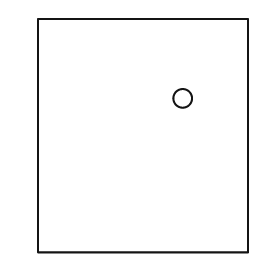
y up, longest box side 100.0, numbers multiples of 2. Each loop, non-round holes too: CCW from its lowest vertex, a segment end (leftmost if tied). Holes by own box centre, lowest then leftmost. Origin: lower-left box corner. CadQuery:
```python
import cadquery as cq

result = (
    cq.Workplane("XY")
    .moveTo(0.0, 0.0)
    .lineTo(90.0, 0.0)
    .lineTo(90.0, 100.0)
    .lineTo(0.0, 100.0)
    .close()
    .moveTo(62.0, 66.0)
    .circle(4.0)
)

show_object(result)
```